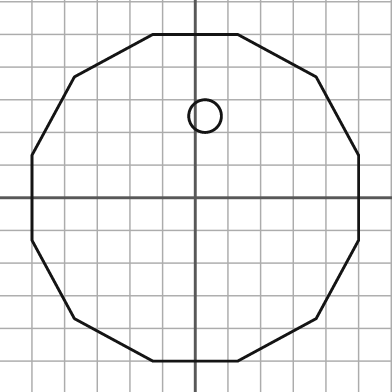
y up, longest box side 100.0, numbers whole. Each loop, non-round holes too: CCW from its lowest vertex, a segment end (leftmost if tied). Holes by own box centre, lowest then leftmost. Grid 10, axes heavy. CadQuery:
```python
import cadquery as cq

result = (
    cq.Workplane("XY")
    .moveTo(-13.0, -50.0)
    .lineTo(13.0, -50.0)
    .lineTo(37.0, -37.0)
    .lineTo(50.0, -13.0)
    .lineTo(50.0, 13.0)
    .lineTo(37.0, 37.0)
    .lineTo(13.0, 50.0)
    .lineTo(-13.0, 50.0)
    .lineTo(-37.0, 37.0)
    .lineTo(-50.0, 13.0)
    .lineTo(-50.0, -13.0)
    .lineTo(-37.0, -37.0)
    .close()
    .moveTo(3.0, 25.0)
    .circle(5.0)
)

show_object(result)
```